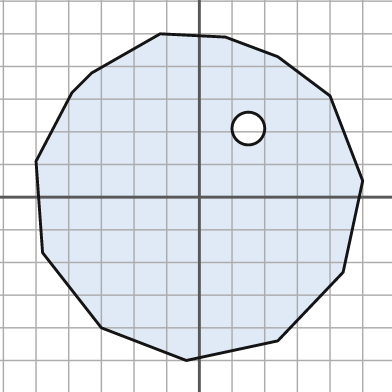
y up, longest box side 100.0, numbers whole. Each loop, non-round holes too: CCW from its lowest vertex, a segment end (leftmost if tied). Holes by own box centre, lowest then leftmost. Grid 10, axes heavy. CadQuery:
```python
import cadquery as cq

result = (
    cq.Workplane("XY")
    .moveTo(-4.0, -50.0)
    .lineTo(24.0, -44.0)
    .lineTo(44.0, -23.0)
    .lineTo(50.0, 5.0)
    .lineTo(40.0, 31.0)
    .lineTo(24.0, 43.0)
    .lineTo(8.0, 49.0)
    .lineTo(-12.0, 50.0)
    .lineTo(-33.0, 38.0)
    .lineTo(-39.0, 32.0)
    .lineTo(-50.0, 11.0)
    .lineTo(-48.0, -17.0)
    .lineTo(-30.0, -40.0)
    .close()
    .moveTo(15.0, 21.0)
    .circle(5.0)
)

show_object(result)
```